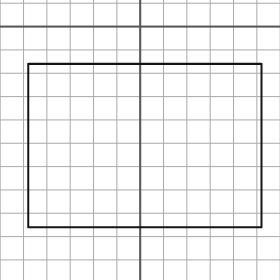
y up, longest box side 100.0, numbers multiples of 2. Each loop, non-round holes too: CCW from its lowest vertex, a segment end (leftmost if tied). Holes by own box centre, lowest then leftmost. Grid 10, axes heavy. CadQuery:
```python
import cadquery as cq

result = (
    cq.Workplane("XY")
    .moveTo(-48.0, -86.0)
    .lineTo(52.0, -86.0)
    .lineTo(52.0, -16.0)
    .lineTo(-48.0, -16.0)
    .close()
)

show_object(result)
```